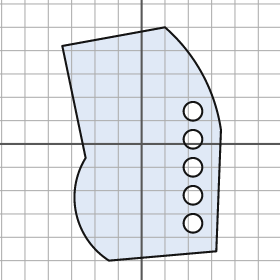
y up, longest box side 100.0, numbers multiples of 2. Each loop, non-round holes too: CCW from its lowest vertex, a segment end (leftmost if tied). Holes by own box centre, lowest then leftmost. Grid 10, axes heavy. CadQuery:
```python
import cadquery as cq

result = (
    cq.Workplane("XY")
    .moveTo(-14.0, -50.0)
    .lineTo(32.0, -46.0)
    .lineTo(34.0, 6.0)
    .threePointArc((26.0, 30.0), (10.0, 50.0))
    .lineTo(-34.0, 42.0)
    .lineTo(-24.0, -6.0)
    .threePointArc((-28.0, -30.0), (-14.0, -50.0))
    .close()
    .moveTo(22.0, -34.0)
    .circle(4.0)
    .moveTo(22.0, -22.0)
    .circle(4.0)
    .moveTo(22.0, -10.0)
    .circle(4.0)
    .moveTo(22.0, 2.0)
    .circle(4.0)
    .moveTo(22.0, 14.0)
    .circle(4.0)
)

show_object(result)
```